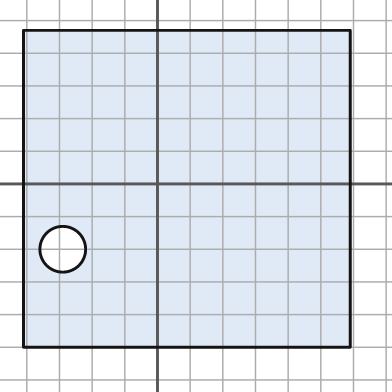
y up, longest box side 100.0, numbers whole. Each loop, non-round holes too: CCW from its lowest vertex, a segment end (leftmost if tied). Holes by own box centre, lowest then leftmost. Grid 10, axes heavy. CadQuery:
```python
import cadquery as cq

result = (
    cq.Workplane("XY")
    .moveTo(-41.0, -50.0)
    .lineTo(59.0, -50.0)
    .lineTo(59.0, 47.0)
    .lineTo(-41.0, 47.0)
    .close()
    .moveTo(-29.0, -20.0)
    .circle(7.0)
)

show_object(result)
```